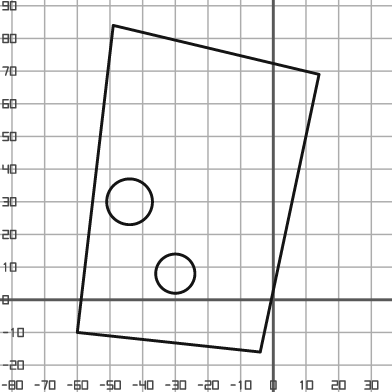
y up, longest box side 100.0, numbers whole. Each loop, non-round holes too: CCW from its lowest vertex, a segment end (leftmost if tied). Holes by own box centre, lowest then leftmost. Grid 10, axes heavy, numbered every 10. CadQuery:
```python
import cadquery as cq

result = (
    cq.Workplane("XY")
    .moveTo(-4.0, -16.0)
    .lineTo(14.0, 69.0)
    .lineTo(-49.0, 84.0)
    .lineTo(-60.0, -10.0)
    .close()
    .moveTo(-30.0, 8.0)
    .circle(6.0)
    .moveTo(-44.0, 30.0)
    .circle(7.0)
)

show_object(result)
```